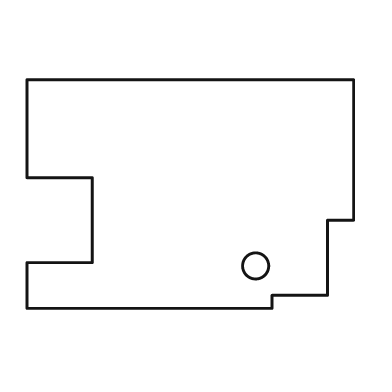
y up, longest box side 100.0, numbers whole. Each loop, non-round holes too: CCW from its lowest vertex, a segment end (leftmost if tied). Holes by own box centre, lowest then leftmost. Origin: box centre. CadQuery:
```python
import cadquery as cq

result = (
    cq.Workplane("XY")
    .moveTo(-50.0, -35.0)
    .lineTo(25.0, -35.0)
    .lineTo(25.0, -31.0)
    .lineTo(42.0, -31.0)
    .lineTo(42.0, -8.0)
    .lineTo(50.0, -8.0)
    .lineTo(50.0, 35.0)
    .lineTo(-50.0, 35.0)
    .lineTo(-50.0, 5.0)
    .lineTo(-30.0, 5.0)
    .lineTo(-30.0, -21.0)
    .lineTo(-50.0, -21.0)
    .close()
    .moveTo(20.0, -22.0)
    .circle(4.0)
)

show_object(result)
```